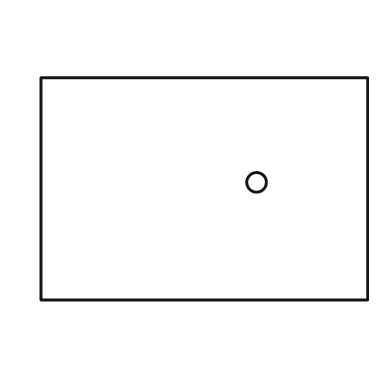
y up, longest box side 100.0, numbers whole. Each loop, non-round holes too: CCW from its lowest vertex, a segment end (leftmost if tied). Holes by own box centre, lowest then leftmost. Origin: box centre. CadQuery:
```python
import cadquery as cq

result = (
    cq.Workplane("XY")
    .moveTo(-50.0, -34.0)
    .lineTo(50.0, -34.0)
    .lineTo(50.0, 34.0)
    .lineTo(-50.0, 34.0)
    .close()
    .moveTo(16.0, 2.0)
    .circle(3.0)
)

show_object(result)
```